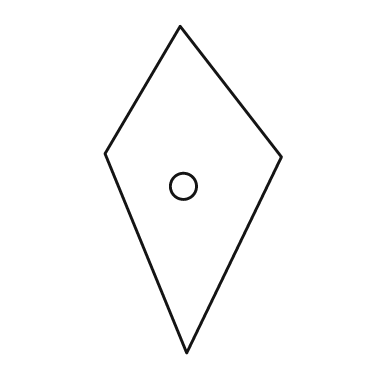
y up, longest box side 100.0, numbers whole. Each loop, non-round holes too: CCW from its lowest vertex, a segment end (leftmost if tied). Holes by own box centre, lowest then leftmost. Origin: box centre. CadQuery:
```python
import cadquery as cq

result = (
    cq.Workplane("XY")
    .moveTo(-2.0, -50.0)
    .lineTo(27.0, 10.0)
    .lineTo(-4.0, 50.0)
    .lineTo(-27.0, 11.0)
    .close()
    .moveTo(-3.0, 1.0)
    .circle(4.0)
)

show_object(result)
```